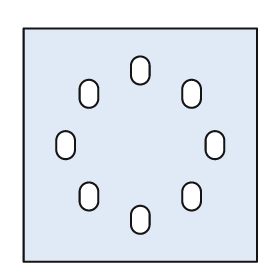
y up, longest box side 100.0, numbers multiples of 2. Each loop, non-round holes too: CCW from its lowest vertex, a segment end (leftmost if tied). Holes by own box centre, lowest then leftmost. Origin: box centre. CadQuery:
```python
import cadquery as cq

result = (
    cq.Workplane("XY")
    .moveTo(-50.0, -50.0)
    .lineTo(50.0, -50.0)
    .lineTo(50.0, 50.0)
    .lineTo(-50.0, 50.0)
    .close()
    .moveTo(-4.0, -34.0)
    .threePointArc((0.0, -38.0), (4.0, -34.0))
    .lineTo(4.0, -30.0)
    .threePointArc((0.0, -26.0), (-4.0, -30.0))
    .close()
    .moveTo(-26.0, -24.0)
    .threePointArc((-22.0, -28.0), (-18.0, -24.0))
    .lineTo(-18.0, -20.0)
    .threePointArc((-22.0, -16.0), (-26.0, -20.0))
    .close()
    .moveTo(18.0, -24.0)
    .threePointArc((22.0, -28.0), (26.0, -24.0))
    .lineTo(26.0, -20.0)
    .threePointArc((22.0, -16.0), (18.0, -20.0))
    .close()
    .moveTo(-36.0, -2.0)
    .threePointArc((-32.0, -6.0), (-28.0, -2.0))
    .lineTo(-28.0, 2.0)
    .threePointArc((-32.0, 6.0), (-36.0, 2.0))
    .close()
    .moveTo(28.0, -2.0)
    .threePointArc((32.0, -6.0), (36.0, -2.0))
    .lineTo(36.0, 2.0)
    .threePointArc((32.0, 6.0), (28.0, 2.0))
    .close()
    .moveTo(-26.0, 20.0)
    .threePointArc((-22.0, 16.0), (-18.0, 20.0))
    .lineTo(-18.0, 24.0)
    .threePointArc((-22.0, 28.0), (-26.0, 24.0))
    .close()
    .moveTo(18.0, 20.0)
    .threePointArc((22.0, 16.0), (26.0, 20.0))
    .lineTo(26.0, 24.0)
    .threePointArc((22.0, 28.0), (18.0, 24.0))
    .close()
    .moveTo(-4.0, 30.0)
    .threePointArc((0.0, 26.0), (4.0, 30.0))
    .lineTo(4.0, 34.0)
    .threePointArc((0.0, 38.0), (-4.0, 34.0))
    .close()
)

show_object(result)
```